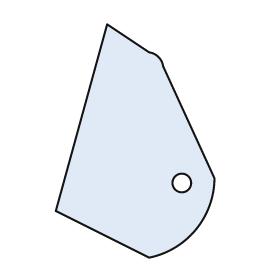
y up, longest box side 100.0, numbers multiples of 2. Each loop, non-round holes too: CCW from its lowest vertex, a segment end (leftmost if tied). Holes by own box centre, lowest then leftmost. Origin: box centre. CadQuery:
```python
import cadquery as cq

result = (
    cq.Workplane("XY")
    .moveTo(6.0, -50.0)
    .threePointArc((26.0, -38.0), (34.0, -16.0))
    .lineTo(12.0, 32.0)
    .threePointArc((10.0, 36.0), (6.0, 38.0))
    .lineTo(-12.0, 50.0)
    .lineTo(-34.0, -30.0)
    .close()
    .moveTo(20.0, -18.0)
    .circle(4.0)
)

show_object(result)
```